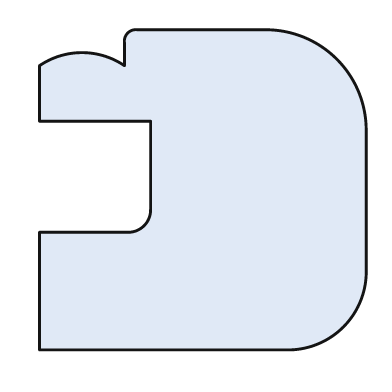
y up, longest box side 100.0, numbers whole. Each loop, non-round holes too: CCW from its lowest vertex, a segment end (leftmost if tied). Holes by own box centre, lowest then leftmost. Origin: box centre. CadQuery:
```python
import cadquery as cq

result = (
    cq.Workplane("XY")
    .moveTo(-50.0, -49.0)
    .lineTo(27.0, -49.0)
    .threePointArc((43.0, -42.0), (50.0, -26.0))
    .lineTo(50.0, 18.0)
    .threePointArc((41.0, 40.0), (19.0, 49.0))
    .lineTo(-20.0, 49.0)
    .threePointArc((-23.0, 48.0), (-24.0, 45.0))
    .lineTo(-24.0, 38.0)
    .threePointArc((-37.0, 42.0), (-50.0, 38.0))
    .lineTo(-50.0, 21.0)
    .lineTo(-16.0, 21.0)
    .lineTo(-16.0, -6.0)
    .threePointArc((-18.0, -11.0), (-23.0, -13.0))
    .lineTo(-50.0, -13.0)
    .close()
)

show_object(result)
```